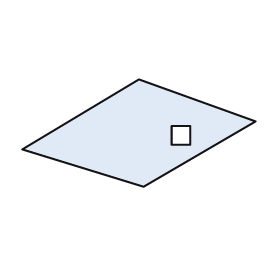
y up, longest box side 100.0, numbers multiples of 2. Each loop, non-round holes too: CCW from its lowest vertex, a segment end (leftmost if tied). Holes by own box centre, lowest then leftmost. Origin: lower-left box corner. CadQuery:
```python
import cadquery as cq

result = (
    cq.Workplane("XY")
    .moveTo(52.0, 0.0)
    .lineTo(100.0, 28.0)
    .lineTo(50.0, 46.0)
    .lineTo(0.0, 16.0)
    .close()
    .moveTo(64.0, 18.0)
    .lineTo(72.0, 18.0)
    .lineTo(72.0, 26.0)
    .lineTo(64.0, 26.0)
    .close()
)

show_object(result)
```